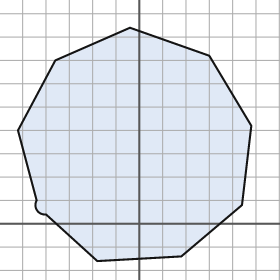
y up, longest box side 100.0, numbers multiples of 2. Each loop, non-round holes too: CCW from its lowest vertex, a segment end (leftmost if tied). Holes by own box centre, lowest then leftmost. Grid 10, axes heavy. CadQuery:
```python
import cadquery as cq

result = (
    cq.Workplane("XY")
    .moveTo(-18.0, -16.0)
    .lineTo(18.0, -14.0)
    .lineTo(44.0, 8.0)
    .lineTo(48.0, 42.0)
    .lineTo(30.0, 72.0)
    .lineTo(-4.0, 84.0)
    .lineTo(-36.0, 70.0)
    .lineTo(-52.0, 40.0)
    .lineTo(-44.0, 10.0)
    .threePointArc((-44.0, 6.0), (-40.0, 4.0))
    .close()
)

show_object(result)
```